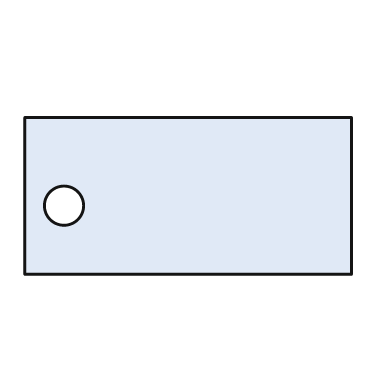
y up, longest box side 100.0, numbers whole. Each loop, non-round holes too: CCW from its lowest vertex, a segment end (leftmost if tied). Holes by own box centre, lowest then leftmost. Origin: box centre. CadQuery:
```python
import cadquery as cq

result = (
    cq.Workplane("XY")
    .moveTo(-50.0, -24.0)
    .lineTo(50.0, -24.0)
    .lineTo(50.0, 24.0)
    .lineTo(-50.0, 24.0)
    .close()
    .moveTo(-38.0, -3.0)
    .circle(6.0)
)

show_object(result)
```